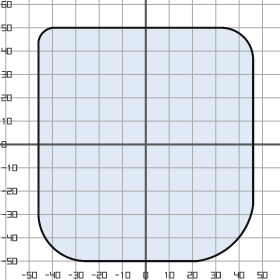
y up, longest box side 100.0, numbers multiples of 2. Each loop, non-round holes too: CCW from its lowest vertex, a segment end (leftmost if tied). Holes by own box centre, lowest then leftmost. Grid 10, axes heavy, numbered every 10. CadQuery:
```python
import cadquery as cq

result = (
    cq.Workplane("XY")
    .moveTo(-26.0, -50.0)
    .lineTo(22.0, -50.0)
    .threePointArc((38.0, -42.0), (46.0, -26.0))
    .lineTo(46.0, 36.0)
    .threePointArc((42.0, 46.0), (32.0, 50.0))
    .lineTo(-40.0, 50.0)
    .threePointArc((-44.0, 48.0), (-46.0, 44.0))
    .lineTo(-46.0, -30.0)
    .threePointArc((-40.0, -44.0), (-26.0, -50.0))
    .close()
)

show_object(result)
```